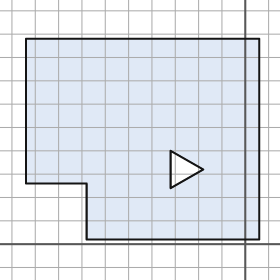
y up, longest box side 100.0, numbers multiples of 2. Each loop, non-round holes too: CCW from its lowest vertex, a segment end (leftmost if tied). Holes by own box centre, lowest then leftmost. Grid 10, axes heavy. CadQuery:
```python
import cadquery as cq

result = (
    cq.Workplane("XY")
    .moveTo(-68.0, 2.0)
    .lineTo(6.0, 2.0)
    .lineTo(6.0, 88.0)
    .lineTo(-94.0, 88.0)
    .lineTo(-94.0, 26.0)
    .lineTo(-68.0, 26.0)
    .close()
    .moveTo(-32.0, 24.0)
    .lineTo(-18.0, 32.0)
    .lineTo(-32.0, 40.0)
    .close()
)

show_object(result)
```